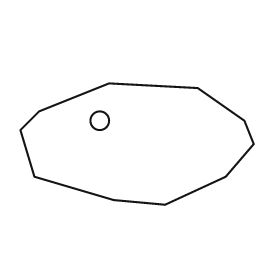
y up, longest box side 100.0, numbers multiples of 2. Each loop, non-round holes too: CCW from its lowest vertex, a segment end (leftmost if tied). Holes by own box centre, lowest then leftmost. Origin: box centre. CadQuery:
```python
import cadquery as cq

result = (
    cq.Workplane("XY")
    .moveTo(12.0, -26.0)
    .lineTo(38.0, -14.0)
    .lineTo(50.0, 0.0)
    .lineTo(46.0, 10.0)
    .lineTo(26.0, 24.0)
    .lineTo(-12.0, 26.0)
    .lineTo(-42.0, 14.0)
    .lineTo(-50.0, 6.0)
    .lineTo(-44.0, -14.0)
    .lineTo(-10.0, -24.0)
    .close()
    .moveTo(-16.0, 10.0)
    .circle(4.0)
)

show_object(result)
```